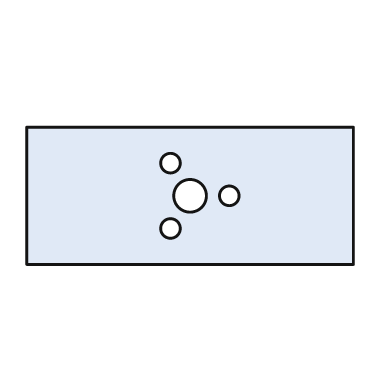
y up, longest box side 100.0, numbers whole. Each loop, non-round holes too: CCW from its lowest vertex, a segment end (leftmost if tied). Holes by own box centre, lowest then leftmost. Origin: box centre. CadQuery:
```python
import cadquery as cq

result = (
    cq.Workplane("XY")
    .moveTo(-50.0, -21.0)
    .lineTo(50.0, -21.0)
    .lineTo(50.0, 21.0)
    .lineTo(-50.0, 21.0)
    .close()
    .moveTo(-6.0, -10.0)
    .circle(3.0)
    .moveTo(0.0, 0.0)
    .circle(5.0)
    .moveTo(12.0, 0.0)
    .circle(3.0)
    .moveTo(-6.0, 10.0)
    .circle(3.0)
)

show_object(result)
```